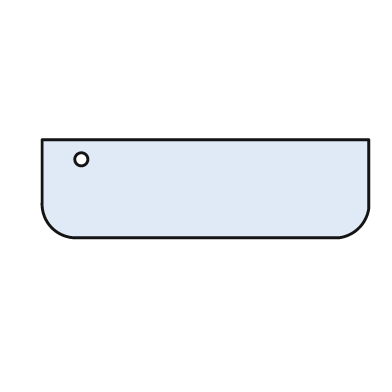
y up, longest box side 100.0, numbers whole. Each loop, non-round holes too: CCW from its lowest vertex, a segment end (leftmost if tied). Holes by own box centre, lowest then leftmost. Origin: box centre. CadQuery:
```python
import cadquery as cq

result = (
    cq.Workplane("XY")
    .moveTo(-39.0, -15.0)
    .lineTo(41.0, -15.0)
    .threePointArc((47.0, -12.0), (50.0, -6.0))
    .lineTo(50.0, 15.0)
    .lineTo(-50.0, 15.0)
    .lineTo(-50.0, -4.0)
    .threePointArc((-47.0, -12.0), (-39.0, -15.0))
    .close()
    .moveTo(-38.0, 9.0)
    .circle(2.0)
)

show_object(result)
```